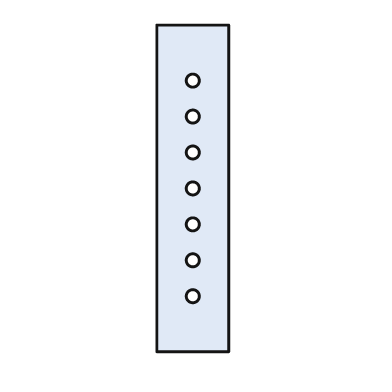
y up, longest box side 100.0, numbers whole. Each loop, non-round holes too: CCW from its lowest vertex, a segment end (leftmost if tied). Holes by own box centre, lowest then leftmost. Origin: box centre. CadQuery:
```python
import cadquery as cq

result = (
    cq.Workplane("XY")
    .moveTo(-11.0, -50.0)
    .lineTo(11.0, -50.0)
    .lineTo(11.0, 50.0)
    .lineTo(-11.0, 50.0)
    .close()
    .moveTo(0.0, -33.0)
    .circle(2.0)
    .moveTo(0.0, -22.0)
    .circle(2.0)
    .moveTo(0.0, -11.0)
    .circle(2.0)
    .moveTo(0.0, 0.0)
    .circle(2.0)
    .moveTo(0.0, 11.0)
    .circle(2.0)
    .moveTo(0.0, 22.0)
    .circle(2.0)
    .moveTo(0.0, 33.0)
    .circle(2.0)
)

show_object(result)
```